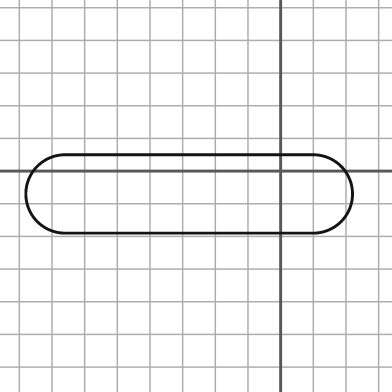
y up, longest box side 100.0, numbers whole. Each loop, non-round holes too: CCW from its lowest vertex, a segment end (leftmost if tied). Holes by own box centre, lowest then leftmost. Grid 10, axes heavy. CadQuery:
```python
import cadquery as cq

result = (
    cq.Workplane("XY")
    .moveTo(-66.0, -19.0)
    .lineTo(10.0, -19.0)
    .threePointArc((22.0, -7.0), (10.0, 5.0))
    .lineTo(-66.0, 5.0)
    .threePointArc((-78.0, -7.0), (-66.0, -19.0))
    .close()
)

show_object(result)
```